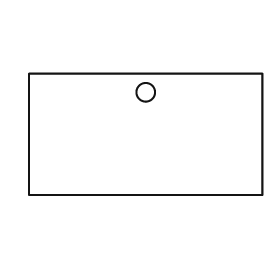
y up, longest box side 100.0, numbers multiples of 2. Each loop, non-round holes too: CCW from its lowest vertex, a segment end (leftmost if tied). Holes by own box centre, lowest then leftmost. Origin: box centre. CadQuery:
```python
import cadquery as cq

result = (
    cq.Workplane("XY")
    .moveTo(-50.0, -26.0)
    .lineTo(50.0, -26.0)
    .lineTo(50.0, 26.0)
    .lineTo(-50.0, 26.0)
    .close()
    .moveTo(0.0, 18.0)
    .circle(4.0)
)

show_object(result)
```